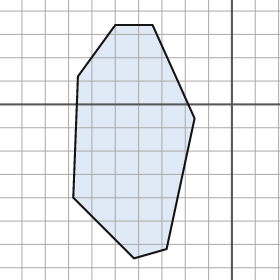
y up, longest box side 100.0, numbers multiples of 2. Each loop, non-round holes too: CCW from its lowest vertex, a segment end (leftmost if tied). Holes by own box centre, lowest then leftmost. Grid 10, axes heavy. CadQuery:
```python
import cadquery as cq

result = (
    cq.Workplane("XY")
    .moveTo(-42.0, -66.0)
    .lineTo(-28.0, -62.0)
    .lineTo(-16.0, -6.0)
    .lineTo(-34.0, 34.0)
    .lineTo(-50.0, 34.0)
    .lineTo(-66.0, 12.0)
    .lineTo(-68.0, -40.0)
    .close()
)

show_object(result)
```